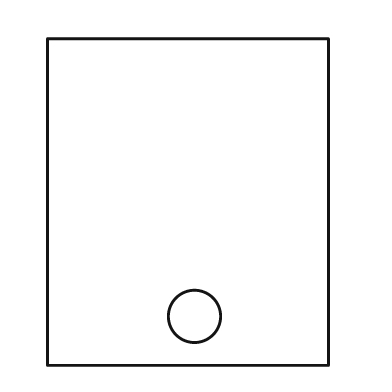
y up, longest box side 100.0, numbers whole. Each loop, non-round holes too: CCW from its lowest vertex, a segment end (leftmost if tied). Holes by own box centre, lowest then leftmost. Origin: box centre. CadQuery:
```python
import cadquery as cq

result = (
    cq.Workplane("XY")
    .moveTo(-43.0, -50.0)
    .lineTo(43.0, -50.0)
    .lineTo(43.0, 50.0)
    .lineTo(-43.0, 50.0)
    .close()
    .moveTo(2.0, -35.0)
    .circle(8.0)
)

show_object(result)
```